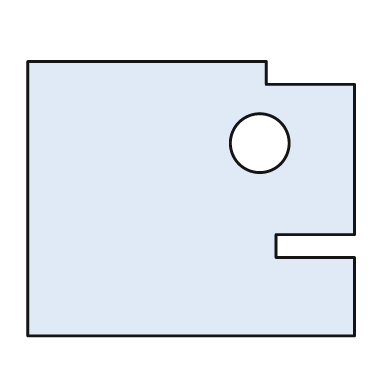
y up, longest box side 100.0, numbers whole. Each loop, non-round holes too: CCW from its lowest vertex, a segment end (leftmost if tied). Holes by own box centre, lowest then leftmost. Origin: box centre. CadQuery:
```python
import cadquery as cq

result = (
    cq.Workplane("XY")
    .moveTo(-50.0, -42.0)
    .lineTo(50.0, -42.0)
    .lineTo(50.0, -18.0)
    .lineTo(26.0, -18.0)
    .lineTo(26.0, -11.0)
    .lineTo(50.0, -11.0)
    .lineTo(50.0, 35.0)
    .lineTo(23.0, 35.0)
    .lineTo(23.0, 42.0)
    .lineTo(-50.0, 42.0)
    .close()
    .moveTo(21.0, 17.0)
    .circle(9.0)
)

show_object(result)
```